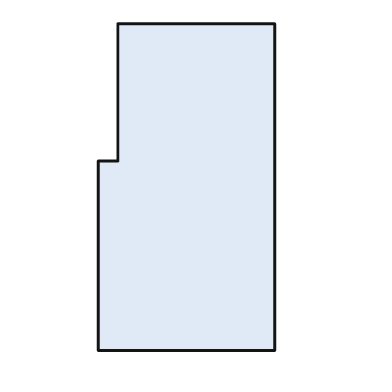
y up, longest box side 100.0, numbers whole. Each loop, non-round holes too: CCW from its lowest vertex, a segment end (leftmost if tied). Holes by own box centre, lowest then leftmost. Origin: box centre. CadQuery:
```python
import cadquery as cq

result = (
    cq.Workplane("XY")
    .moveTo(-27.0, -50.0)
    .lineTo(27.0, -50.0)
    .lineTo(27.0, 50.0)
    .lineTo(-21.0, 50.0)
    .lineTo(-21.0, 8.0)
    .lineTo(-27.0, 8.0)
    .close()
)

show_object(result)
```